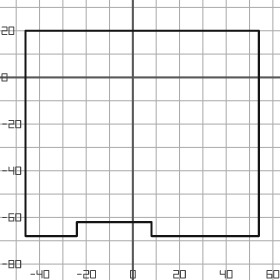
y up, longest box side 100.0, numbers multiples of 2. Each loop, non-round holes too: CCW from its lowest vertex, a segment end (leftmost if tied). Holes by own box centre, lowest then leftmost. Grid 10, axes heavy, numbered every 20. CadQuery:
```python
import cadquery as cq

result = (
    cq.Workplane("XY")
    .moveTo(-46.0, -68.0)
    .lineTo(-24.0, -68.0)
    .lineTo(-24.0, -62.0)
    .lineTo(8.0, -62.0)
    .lineTo(8.0, -68.0)
    .lineTo(54.0, -68.0)
    .lineTo(54.0, 20.0)
    .lineTo(-46.0, 20.0)
    .close()
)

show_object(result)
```